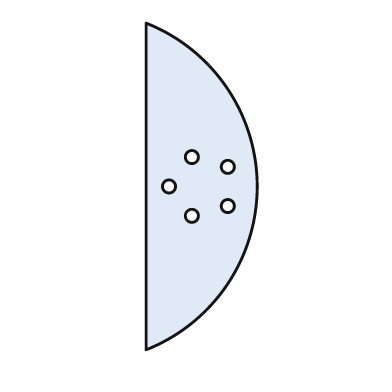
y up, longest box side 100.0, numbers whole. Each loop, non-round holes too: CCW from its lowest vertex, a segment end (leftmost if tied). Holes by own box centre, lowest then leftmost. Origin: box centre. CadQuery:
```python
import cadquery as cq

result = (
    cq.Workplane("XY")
    .moveTo(-17.0, -50.0)
    .threePointArc((17.0, 0.0), (-17.0, 50.0))
    .close()
    .moveTo(-3.0, -9.0)
    .circle(2.0)
    .moveTo(8.0, -6.0)
    .circle(2.0)
    .moveTo(-10.0, 0.0)
    .circle(2.0)
    .moveTo(8.0, 6.0)
    .circle(2.0)
    .moveTo(-3.0, 9.0)
    .circle(2.0)
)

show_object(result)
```